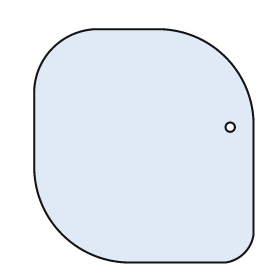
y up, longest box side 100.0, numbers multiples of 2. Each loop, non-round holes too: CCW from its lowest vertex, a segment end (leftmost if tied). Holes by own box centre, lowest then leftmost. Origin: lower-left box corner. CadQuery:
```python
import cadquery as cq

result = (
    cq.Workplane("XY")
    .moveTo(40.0, 0.0)
    .lineTo(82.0, 0.0)
    .threePointArc((90.0, 4.0), (94.0, 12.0))
    .lineTo(94.0, 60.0)
    .threePointArc((82.0, 88.0), (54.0, 100.0))
    .lineTo(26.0, 100.0)
    .threePointArc((8.0, 92.0), (0.0, 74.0))
    .lineTo(0.0, 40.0)
    .threePointArc((12.0, 12.0), (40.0, 0.0))
    .close()
    .moveTo(84.0, 58.0)
    .circle(2.0)
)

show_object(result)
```